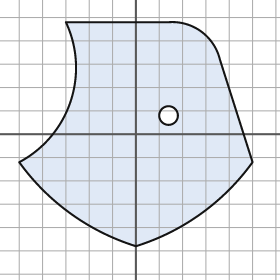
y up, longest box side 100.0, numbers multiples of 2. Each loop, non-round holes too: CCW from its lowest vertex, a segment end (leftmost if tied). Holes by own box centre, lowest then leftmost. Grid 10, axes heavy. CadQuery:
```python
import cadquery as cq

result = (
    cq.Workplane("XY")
    .moveTo(0.0, -48.0)
    .threePointArc((28.0, -34.0), (50.0, -12.0))
    .lineTo(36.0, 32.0)
    .threePointArc((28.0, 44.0), (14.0, 48.0))
    .lineTo(-30.0, 48.0)
    .threePointArc((-28.0, 14.0), (-50.0, -12.0))
    .threePointArc((-28.0, -34.0), (0.0, -48.0))
    .close()
    .moveTo(14.0, 8.0)
    .circle(4.0)
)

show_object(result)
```